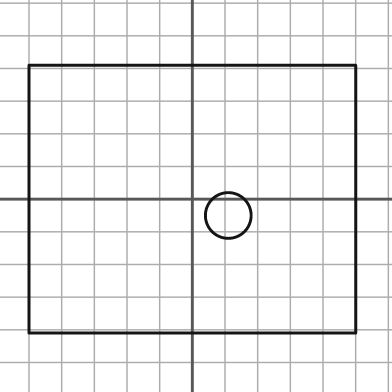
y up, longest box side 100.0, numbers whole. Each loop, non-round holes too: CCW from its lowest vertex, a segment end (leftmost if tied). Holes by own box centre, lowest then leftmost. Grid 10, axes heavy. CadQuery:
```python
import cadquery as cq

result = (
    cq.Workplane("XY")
    .moveTo(-50.0, -41.0)
    .lineTo(50.0, -41.0)
    .lineTo(50.0, 41.0)
    .lineTo(-50.0, 41.0)
    .close()
    .moveTo(11.0, -5.0)
    .circle(7.0)
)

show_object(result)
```